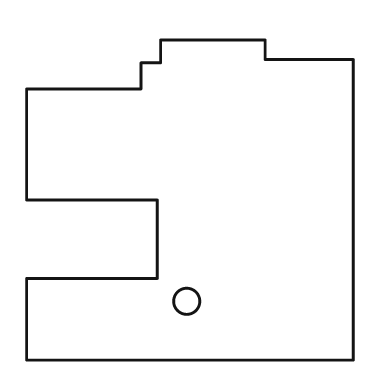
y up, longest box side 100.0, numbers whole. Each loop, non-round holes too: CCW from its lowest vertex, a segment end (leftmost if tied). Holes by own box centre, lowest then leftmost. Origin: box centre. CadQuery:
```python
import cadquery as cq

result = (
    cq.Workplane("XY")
    .moveTo(-50.0, -49.0)
    .lineTo(50.0, -49.0)
    .lineTo(50.0, 43.0)
    .lineTo(23.0, 43.0)
    .lineTo(23.0, 49.0)
    .lineTo(-9.0, 49.0)
    .lineTo(-9.0, 42.0)
    .lineTo(-15.0, 42.0)
    .lineTo(-15.0, 34.0)
    .lineTo(-50.0, 34.0)
    .lineTo(-50.0, 0.0)
    .lineTo(-10.0, 0.0)
    .lineTo(-10.0, -24.0)
    .lineTo(-50.0, -24.0)
    .close()
    .moveTo(-1.0, -31.0)
    .circle(4.0)
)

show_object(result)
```